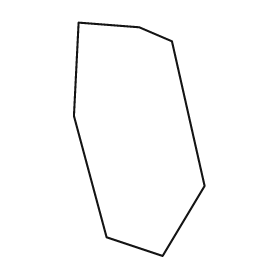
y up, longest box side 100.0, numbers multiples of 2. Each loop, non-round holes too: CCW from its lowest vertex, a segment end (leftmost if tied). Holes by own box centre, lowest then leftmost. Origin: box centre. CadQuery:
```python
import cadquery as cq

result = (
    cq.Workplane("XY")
    .moveTo(10.0, -50.0)
    .lineTo(28.0, -20.0)
    .lineTo(14.0, 42.0)
    .lineTo(0.0, 48.0)
    .lineTo(-26.0, 50.0)
    .lineTo(-28.0, 10.0)
    .lineTo(-14.0, -42.0)
    .close()
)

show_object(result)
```